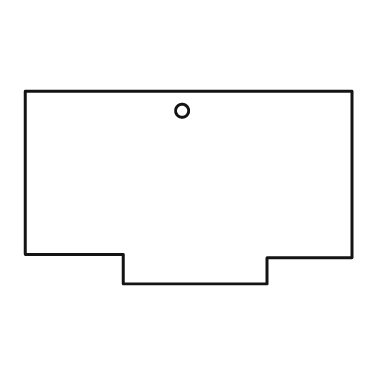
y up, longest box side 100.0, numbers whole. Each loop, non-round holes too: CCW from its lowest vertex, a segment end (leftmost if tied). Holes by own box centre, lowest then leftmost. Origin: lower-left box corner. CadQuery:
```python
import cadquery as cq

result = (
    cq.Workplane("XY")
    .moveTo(30.0, 0.0)
    .lineTo(74.0, 0.0)
    .lineTo(74.0, 8.0)
    .lineTo(100.0, 8.0)
    .lineTo(100.0, 59.0)
    .lineTo(0.0, 59.0)
    .lineTo(0.0, 9.0)
    .lineTo(30.0, 9.0)
    .close()
    .moveTo(48.0, 53.0)
    .circle(2.0)
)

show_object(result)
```